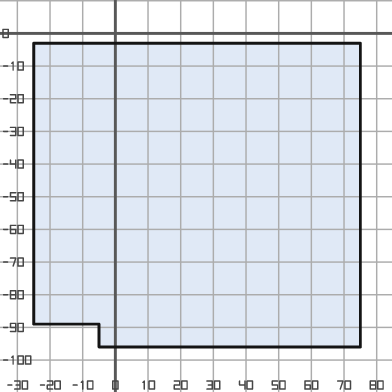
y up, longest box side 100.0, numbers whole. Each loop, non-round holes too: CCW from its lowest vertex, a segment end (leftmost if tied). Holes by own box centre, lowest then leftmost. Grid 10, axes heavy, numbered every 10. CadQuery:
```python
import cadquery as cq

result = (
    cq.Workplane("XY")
    .moveTo(-5.0, -96.0)
    .lineTo(75.0, -96.0)
    .lineTo(75.0, -3.0)
    .lineTo(-25.0, -3.0)
    .lineTo(-25.0, -89.0)
    .lineTo(-5.0, -89.0)
    .close()
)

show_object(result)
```